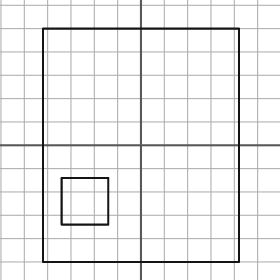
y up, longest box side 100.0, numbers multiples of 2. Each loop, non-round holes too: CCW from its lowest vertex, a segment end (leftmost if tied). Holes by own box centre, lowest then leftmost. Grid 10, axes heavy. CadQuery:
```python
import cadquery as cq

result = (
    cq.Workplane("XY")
    .moveTo(-42.0, -50.0)
    .lineTo(42.0, -50.0)
    .lineTo(42.0, 50.0)
    .lineTo(-42.0, 50.0)
    .close()
    .moveTo(-34.0, -34.0)
    .lineTo(-14.0, -34.0)
    .lineTo(-14.0, -14.0)
    .lineTo(-34.0, -14.0)
    .close()
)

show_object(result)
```